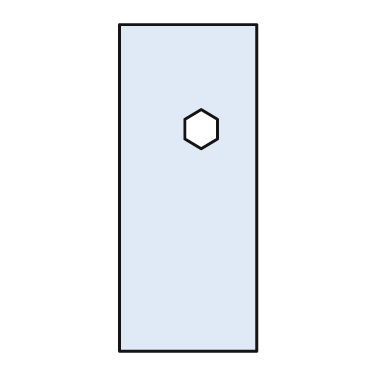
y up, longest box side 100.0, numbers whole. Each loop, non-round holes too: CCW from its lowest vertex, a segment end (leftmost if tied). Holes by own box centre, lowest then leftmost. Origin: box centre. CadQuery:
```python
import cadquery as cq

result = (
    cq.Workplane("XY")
    .moveTo(-21.0, -50.0)
    .lineTo(21.0, -50.0)
    .lineTo(21.0, 50.0)
    .lineTo(-21.0, 50.0)
    .close()
    .moveTo(4.0, 12.0)
    .lineTo(9.0, 15.0)
    .lineTo(9.0, 21.0)
    .lineTo(4.0, 24.0)
    .lineTo(-1.0, 21.0)
    .lineTo(-1.0, 15.0)
    .close()
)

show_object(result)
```